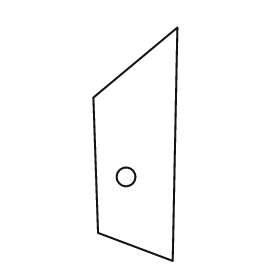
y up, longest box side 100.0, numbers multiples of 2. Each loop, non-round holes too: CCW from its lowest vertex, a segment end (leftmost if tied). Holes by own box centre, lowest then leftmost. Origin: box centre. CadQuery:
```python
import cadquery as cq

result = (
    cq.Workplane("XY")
    .moveTo(16.0, -50.0)
    .lineTo(18.0, 50.0)
    .lineTo(-18.0, 20.0)
    .lineTo(-16.0, -38.0)
    .close()
    .moveTo(-4.0, -14.0)
    .circle(4.0)
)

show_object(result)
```